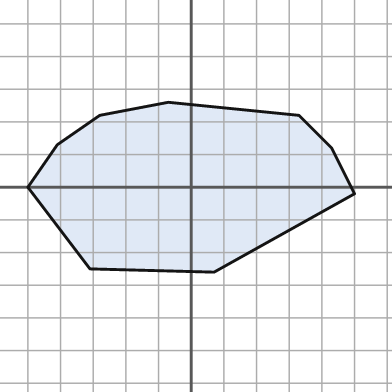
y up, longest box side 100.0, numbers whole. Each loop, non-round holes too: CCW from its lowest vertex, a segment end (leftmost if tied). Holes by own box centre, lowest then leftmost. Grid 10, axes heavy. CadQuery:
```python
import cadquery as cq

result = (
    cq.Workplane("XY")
    .moveTo(7.0, -26.0)
    .lineTo(50.0, -2.0)
    .lineTo(43.0, 12.0)
    .lineTo(33.0, 22.0)
    .lineTo(-7.0, 26.0)
    .lineTo(-28.0, 22.0)
    .lineTo(-41.0, 13.0)
    .lineTo(-50.0, 0.0)
    .lineTo(-31.0, -25.0)
    .close()
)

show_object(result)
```